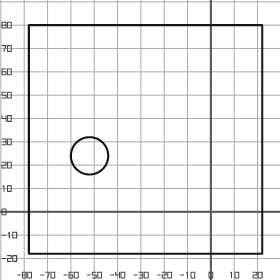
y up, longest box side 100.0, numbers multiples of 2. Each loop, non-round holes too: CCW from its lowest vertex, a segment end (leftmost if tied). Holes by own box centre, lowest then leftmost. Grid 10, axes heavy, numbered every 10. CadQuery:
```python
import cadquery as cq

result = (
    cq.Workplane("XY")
    .moveTo(-78.0, -18.0)
    .lineTo(22.0, -18.0)
    .lineTo(22.0, 80.0)
    .lineTo(-78.0, 80.0)
    .close()
    .moveTo(-52.0, 24.0)
    .circle(8.0)
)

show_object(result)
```